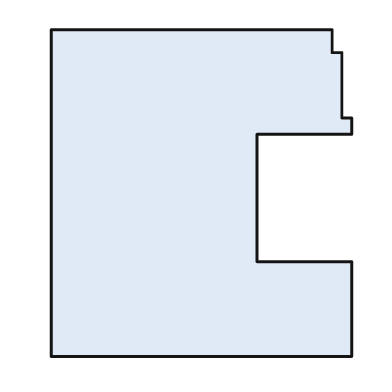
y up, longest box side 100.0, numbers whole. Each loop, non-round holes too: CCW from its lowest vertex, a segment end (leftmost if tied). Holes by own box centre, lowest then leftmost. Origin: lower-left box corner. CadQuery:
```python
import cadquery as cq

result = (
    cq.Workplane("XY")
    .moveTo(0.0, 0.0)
    .lineTo(92.0, 0.0)
    .lineTo(92.0, 29.0)
    .lineTo(63.0, 29.0)
    .lineTo(63.0, 68.0)
    .lineTo(92.0, 68.0)
    .lineTo(92.0, 73.0)
    .lineTo(89.0, 73.0)
    .lineTo(89.0, 93.0)
    .lineTo(86.0, 93.0)
    .lineTo(86.0, 100.0)
    .lineTo(0.0, 100.0)
    .close()
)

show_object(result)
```